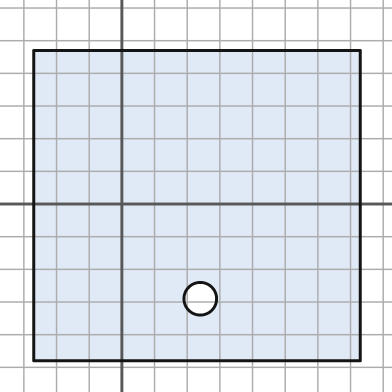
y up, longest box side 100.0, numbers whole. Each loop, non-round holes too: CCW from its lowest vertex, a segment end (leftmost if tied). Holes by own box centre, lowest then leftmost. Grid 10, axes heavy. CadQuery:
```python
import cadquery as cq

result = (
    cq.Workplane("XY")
    .moveTo(-27.0, -48.0)
    .lineTo(73.0, -48.0)
    .lineTo(73.0, 47.0)
    .lineTo(-27.0, 47.0)
    .close()
    .moveTo(24.0, -29.0)
    .circle(5.0)
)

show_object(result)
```